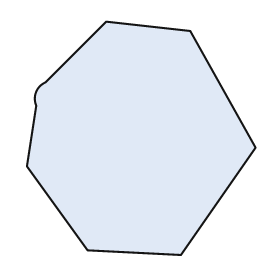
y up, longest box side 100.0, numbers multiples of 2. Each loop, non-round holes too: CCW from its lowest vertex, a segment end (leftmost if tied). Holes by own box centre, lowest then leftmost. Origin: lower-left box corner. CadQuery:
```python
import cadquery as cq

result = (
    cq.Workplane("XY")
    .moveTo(66.0, 0.0)
    .lineTo(98.0, 46.0)
    .lineTo(70.0, 96.0)
    .lineTo(34.0, 100.0)
    .lineTo(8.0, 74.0)
    .threePointArc((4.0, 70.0), (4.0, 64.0))
    .lineTo(0.0, 38.0)
    .lineTo(26.0, 2.0)
    .close()
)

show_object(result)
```